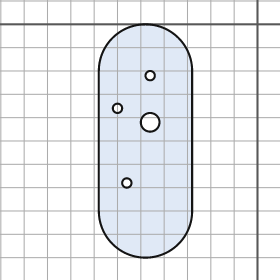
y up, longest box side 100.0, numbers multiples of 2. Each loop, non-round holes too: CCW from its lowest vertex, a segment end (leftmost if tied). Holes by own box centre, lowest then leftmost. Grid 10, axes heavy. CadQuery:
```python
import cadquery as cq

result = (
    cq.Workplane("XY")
    .moveTo(-68.0, -80.0)
    .threePointArc((-48.0, -100.0), (-28.0, -80.0))
    .lineTo(-28.0, -20.0)
    .threePointArc((-48.0, 0.0), (-68.0, -20.0))
    .close()
    .moveTo(-56.0, -68.0)
    .circle(2.0)
    .moveTo(-46.0, -42.0)
    .circle(4.0)
    .moveTo(-60.0, -36.0)
    .circle(2.0)
    .moveTo(-46.0, -22.0)
    .circle(2.0)
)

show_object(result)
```